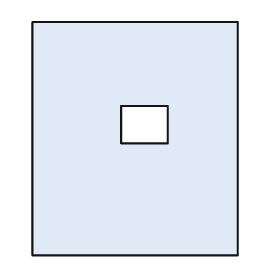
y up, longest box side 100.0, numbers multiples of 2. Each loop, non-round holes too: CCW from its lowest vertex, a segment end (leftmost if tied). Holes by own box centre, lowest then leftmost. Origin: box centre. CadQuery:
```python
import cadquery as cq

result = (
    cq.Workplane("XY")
    .moveTo(-44.0, -50.0)
    .lineTo(44.0, -50.0)
    .lineTo(44.0, 50.0)
    .lineTo(-44.0, 50.0)
    .close()
    .moveTo(-6.0, -2.0)
    .lineTo(14.0, -2.0)
    .lineTo(14.0, 14.0)
    .lineTo(-6.0, 14.0)
    .close()
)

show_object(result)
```